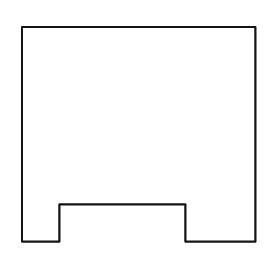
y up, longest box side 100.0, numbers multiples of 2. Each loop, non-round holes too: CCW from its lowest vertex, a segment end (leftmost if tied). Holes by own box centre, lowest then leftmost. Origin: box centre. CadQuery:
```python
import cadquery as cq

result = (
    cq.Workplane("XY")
    .moveTo(-50.0, -46.0)
    .lineTo(-34.0, -46.0)
    .lineTo(-34.0, -30.0)
    .lineTo(20.0, -30.0)
    .lineTo(20.0, -46.0)
    .lineTo(50.0, -46.0)
    .lineTo(50.0, 46.0)
    .lineTo(-50.0, 46.0)
    .close()
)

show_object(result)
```